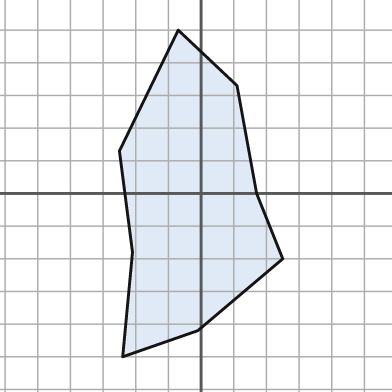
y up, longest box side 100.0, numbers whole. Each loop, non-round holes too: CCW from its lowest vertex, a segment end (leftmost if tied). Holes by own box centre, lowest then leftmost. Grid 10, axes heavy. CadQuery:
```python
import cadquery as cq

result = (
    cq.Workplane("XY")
    .moveTo(-24.0, -50.0)
    .lineTo(-1.0, -42.0)
    .lineTo(25.0, -20.0)
    .lineTo(17.0, 0.0)
    .lineTo(11.0, 33.0)
    .lineTo(-7.0, 50.0)
    .lineTo(-25.0, 13.0)
    .lineTo(-21.0, -18.0)
    .close()
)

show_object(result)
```